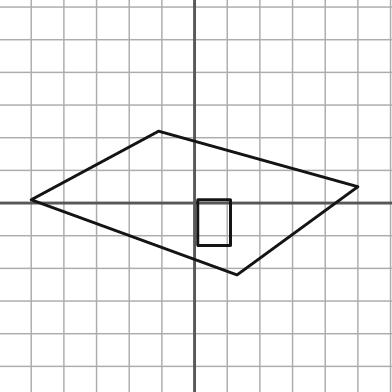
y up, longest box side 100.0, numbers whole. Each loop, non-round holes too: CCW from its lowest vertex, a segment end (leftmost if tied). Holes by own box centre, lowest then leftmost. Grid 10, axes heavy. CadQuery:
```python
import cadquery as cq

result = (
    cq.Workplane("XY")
    .moveTo(13.0, -22.0)
    .lineTo(50.0, 5.0)
    .lineTo(-11.0, 22.0)
    .lineTo(-50.0, 1.0)
    .close()
    .moveTo(1.0, -13.0)
    .lineTo(11.0, -13.0)
    .lineTo(11.0, 1.0)
    .lineTo(1.0, 1.0)
    .close()
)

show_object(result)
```